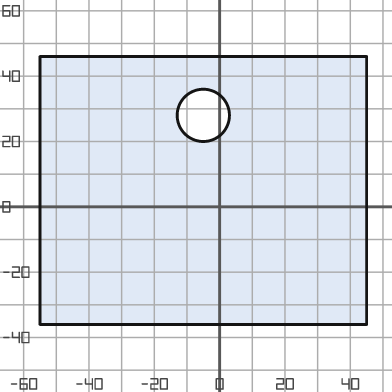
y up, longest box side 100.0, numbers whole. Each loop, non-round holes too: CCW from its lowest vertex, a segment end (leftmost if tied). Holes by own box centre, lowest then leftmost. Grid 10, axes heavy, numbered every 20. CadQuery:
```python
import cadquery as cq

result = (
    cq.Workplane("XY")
    .moveTo(-55.0, -36.0)
    .lineTo(45.0, -36.0)
    .lineTo(45.0, 46.0)
    .lineTo(-55.0, 46.0)
    .close()
    .moveTo(-5.0, 28.0)
    .circle(8.0)
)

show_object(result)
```